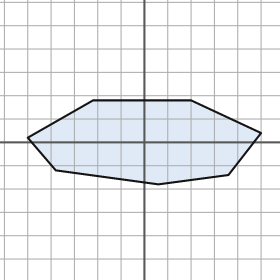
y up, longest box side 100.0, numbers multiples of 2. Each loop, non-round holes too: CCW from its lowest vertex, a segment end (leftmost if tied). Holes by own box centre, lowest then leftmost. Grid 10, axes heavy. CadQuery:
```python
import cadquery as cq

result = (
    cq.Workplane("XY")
    .moveTo(6.0, -18.0)
    .lineTo(36.0, -14.0)
    .lineTo(50.0, 4.0)
    .lineTo(20.0, 18.0)
    .lineTo(-22.0, 18.0)
    .lineTo(-50.0, 2.0)
    .lineTo(-38.0, -12.0)
    .close()
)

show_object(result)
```